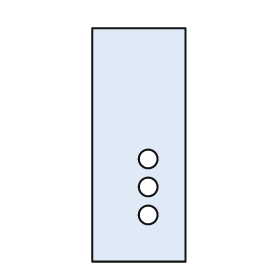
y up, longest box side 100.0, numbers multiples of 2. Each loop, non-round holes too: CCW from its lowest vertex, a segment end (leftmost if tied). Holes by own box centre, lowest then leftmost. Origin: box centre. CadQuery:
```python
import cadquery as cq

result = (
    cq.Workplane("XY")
    .moveTo(-20.0, -50.0)
    .lineTo(20.0, -50.0)
    .lineTo(20.0, 50.0)
    .lineTo(-20.0, 50.0)
    .close()
    .moveTo(4.0, -30.0)
    .circle(4.0)
    .moveTo(4.0, -18.0)
    .circle(4.0)
    .moveTo(4.0, -6.0)
    .circle(4.0)
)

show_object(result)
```